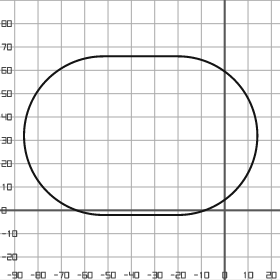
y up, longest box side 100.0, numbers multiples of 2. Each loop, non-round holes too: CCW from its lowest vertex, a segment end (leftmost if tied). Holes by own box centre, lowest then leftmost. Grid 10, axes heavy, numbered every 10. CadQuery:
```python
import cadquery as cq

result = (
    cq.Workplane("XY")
    .moveTo(-52.0, -2.0)
    .lineTo(-20.0, -2.0)
    .threePointArc((14.0, 32.0), (-20.0, 66.0))
    .lineTo(-52.0, 66.0)
    .threePointArc((-86.0, 32.0), (-52.0, -2.0))
    .close()
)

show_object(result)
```